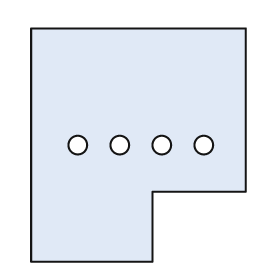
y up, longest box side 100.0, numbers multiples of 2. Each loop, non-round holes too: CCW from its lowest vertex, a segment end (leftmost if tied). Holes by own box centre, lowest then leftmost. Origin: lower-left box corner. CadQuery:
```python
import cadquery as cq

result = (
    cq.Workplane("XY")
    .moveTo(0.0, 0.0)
    .lineTo(52.0, 0.0)
    .lineTo(52.0, 30.0)
    .lineTo(92.0, 30.0)
    .lineTo(92.0, 100.0)
    .lineTo(0.0, 100.0)
    .close()
    .moveTo(20.0, 50.0)
    .circle(4.0)
    .moveTo(38.0, 50.0)
    .circle(4.0)
    .moveTo(56.0, 50.0)
    .circle(4.0)
    .moveTo(74.0, 50.0)
    .circle(4.0)
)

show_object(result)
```